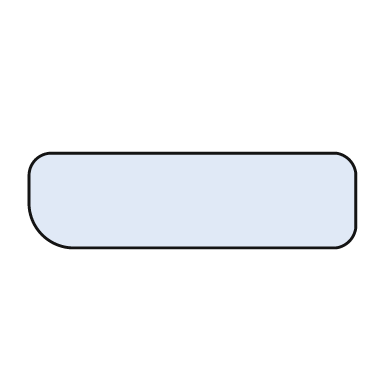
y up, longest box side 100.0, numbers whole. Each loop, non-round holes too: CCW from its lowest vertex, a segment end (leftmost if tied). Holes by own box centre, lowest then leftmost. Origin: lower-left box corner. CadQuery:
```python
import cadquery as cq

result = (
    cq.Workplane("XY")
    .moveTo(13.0, 0.0)
    .lineTo(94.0, 0.0)
    .threePointArc((98.0, 2.0), (100.0, 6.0))
    .lineTo(100.0, 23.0)
    .threePointArc((98.0, 27.0), (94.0, 29.0))
    .lineTo(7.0, 29.0)
    .threePointArc((2.0, 27.0), (0.0, 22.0))
    .lineTo(0.0, 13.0)
    .threePointArc((4.0, 4.0), (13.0, 0.0))
    .close()
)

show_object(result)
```